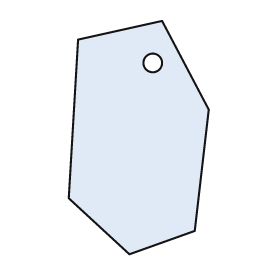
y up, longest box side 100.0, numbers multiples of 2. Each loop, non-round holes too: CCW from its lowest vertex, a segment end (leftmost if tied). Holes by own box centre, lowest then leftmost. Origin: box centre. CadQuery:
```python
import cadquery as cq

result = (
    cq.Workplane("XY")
    .moveTo(-4.0, -50.0)
    .lineTo(24.0, -40.0)
    .lineTo(30.0, 12.0)
    .lineTo(10.0, 50.0)
    .lineTo(-26.0, 42.0)
    .lineTo(-30.0, -26.0)
    .close()
    .moveTo(6.0, 32.0)
    .circle(4.0)
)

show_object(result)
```